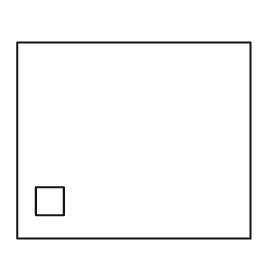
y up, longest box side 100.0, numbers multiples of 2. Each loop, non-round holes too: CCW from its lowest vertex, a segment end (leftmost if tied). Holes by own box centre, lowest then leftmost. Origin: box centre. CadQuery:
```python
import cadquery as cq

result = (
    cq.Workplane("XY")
    .moveTo(-50.0, -42.0)
    .lineTo(50.0, -42.0)
    .lineTo(50.0, 42.0)
    .lineTo(-50.0, 42.0)
    .close()
    .moveTo(-42.0, -32.0)
    .lineTo(-30.0, -32.0)
    .lineTo(-30.0, -20.0)
    .lineTo(-42.0, -20.0)
    .close()
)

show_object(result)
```